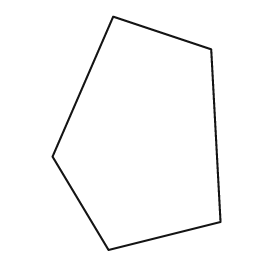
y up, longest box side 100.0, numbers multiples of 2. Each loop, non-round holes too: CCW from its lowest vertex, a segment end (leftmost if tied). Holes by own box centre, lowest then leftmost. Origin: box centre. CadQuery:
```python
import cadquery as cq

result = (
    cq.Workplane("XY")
    .moveTo(-12.0, -50.0)
    .lineTo(36.0, -38.0)
    .lineTo(32.0, 36.0)
    .lineTo(-10.0, 50.0)
    .lineTo(-36.0, -10.0)
    .close()
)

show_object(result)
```